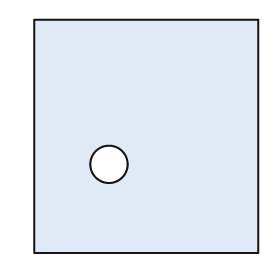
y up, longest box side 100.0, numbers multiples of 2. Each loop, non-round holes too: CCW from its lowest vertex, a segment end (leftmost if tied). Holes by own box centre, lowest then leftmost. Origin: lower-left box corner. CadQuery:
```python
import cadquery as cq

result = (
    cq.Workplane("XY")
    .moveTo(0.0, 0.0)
    .lineTo(96.0, 0.0)
    .lineTo(96.0, 100.0)
    .lineTo(0.0, 100.0)
    .close()
    .moveTo(32.0, 38.0)
    .circle(8.0)
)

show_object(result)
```